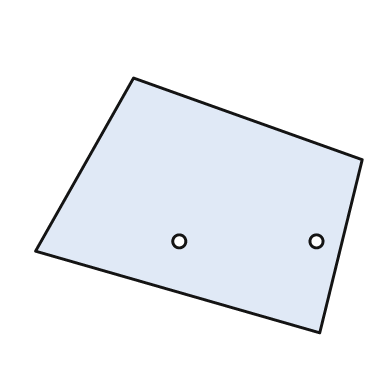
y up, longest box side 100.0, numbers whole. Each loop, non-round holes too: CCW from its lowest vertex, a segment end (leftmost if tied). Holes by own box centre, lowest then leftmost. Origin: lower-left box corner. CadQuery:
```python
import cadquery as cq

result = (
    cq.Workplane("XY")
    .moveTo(87.0, 0.0)
    .lineTo(100.0, 53.0)
    .lineTo(30.0, 78.0)
    .lineTo(0.0, 25.0)
    .close()
    .moveTo(44.0, 28.0)
    .circle(2.0)
    .moveTo(86.0, 28.0)
    .circle(2.0)
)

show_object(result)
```